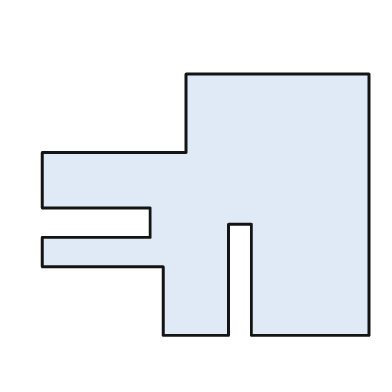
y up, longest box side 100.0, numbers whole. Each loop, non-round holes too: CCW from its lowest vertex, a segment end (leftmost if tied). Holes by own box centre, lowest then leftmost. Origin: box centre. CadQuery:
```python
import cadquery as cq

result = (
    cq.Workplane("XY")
    .moveTo(-13.0, -40.0)
    .lineTo(7.0, -40.0)
    .lineTo(7.0, -6.0)
    .lineTo(14.0, -6.0)
    .lineTo(14.0, -40.0)
    .lineTo(50.0, -40.0)
    .lineTo(50.0, 40.0)
    .lineTo(-6.0, 40.0)
    .lineTo(-6.0, 16.0)
    .lineTo(-50.0, 16.0)
    .lineTo(-50.0, -1.0)
    .lineTo(-17.0, -1.0)
    .lineTo(-17.0, -10.0)
    .lineTo(-50.0, -10.0)
    .lineTo(-50.0, -19.0)
    .lineTo(-13.0, -19.0)
    .close()
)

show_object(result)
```